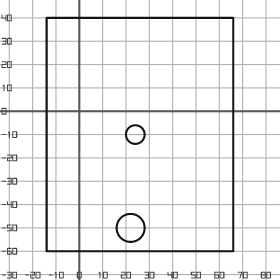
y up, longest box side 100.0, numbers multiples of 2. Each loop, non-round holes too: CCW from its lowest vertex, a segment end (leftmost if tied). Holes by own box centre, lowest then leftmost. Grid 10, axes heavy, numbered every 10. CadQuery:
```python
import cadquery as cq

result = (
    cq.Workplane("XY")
    .moveTo(-14.0, -60.0)
    .lineTo(66.0, -60.0)
    .lineTo(66.0, 40.0)
    .lineTo(-14.0, 40.0)
    .close()
    .moveTo(22.0, -50.0)
    .circle(6.0)
    .moveTo(24.0, -10.0)
    .circle(4.0)
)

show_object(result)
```